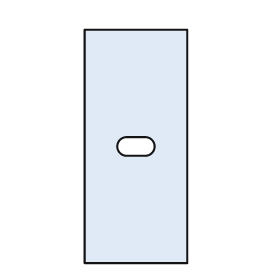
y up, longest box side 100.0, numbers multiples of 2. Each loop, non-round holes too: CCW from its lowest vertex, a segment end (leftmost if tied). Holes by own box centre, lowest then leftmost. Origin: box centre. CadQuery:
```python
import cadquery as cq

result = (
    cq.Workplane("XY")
    .moveTo(-22.0, -50.0)
    .lineTo(22.0, -50.0)
    .lineTo(22.0, 50.0)
    .lineTo(-22.0, 50.0)
    .close()
    .moveTo(-4.0, -4.0)
    .lineTo(4.0, -4.0)
    .threePointArc((8.0, 0.0), (4.0, 4.0))
    .lineTo(-4.0, 4.0)
    .threePointArc((-8.0, 0.0), (-4.0, -4.0))
    .close()
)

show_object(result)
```